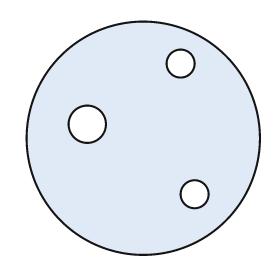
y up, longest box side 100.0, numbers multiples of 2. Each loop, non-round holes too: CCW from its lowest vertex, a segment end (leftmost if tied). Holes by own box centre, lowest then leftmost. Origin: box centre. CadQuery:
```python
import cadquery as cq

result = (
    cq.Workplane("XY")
    .moveTo(0.0, 0.0)
    .circle(50.0)
    .moveTo(22.0, -24.0)
    .circle(6.0)
    .moveTo(-24.0, 6.0)
    .circle(8.0)
    .moveTo(16.0, 32.0)
    .circle(6.0)
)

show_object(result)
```